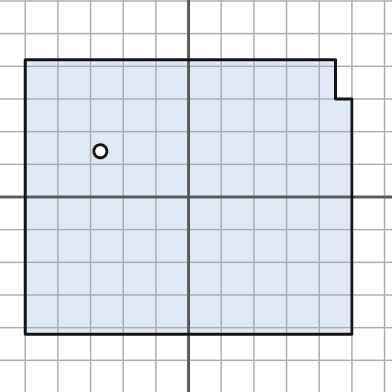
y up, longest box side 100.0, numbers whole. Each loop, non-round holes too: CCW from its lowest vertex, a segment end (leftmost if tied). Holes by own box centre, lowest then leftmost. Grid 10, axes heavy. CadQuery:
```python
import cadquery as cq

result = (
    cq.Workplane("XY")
    .moveTo(-50.0, -42.0)
    .lineTo(50.0, -42.0)
    .lineTo(50.0, 30.0)
    .lineTo(45.0, 30.0)
    .lineTo(45.0, 42.0)
    .lineTo(-50.0, 42.0)
    .close()
    .moveTo(-27.0, 14.0)
    .circle(2.0)
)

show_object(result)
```